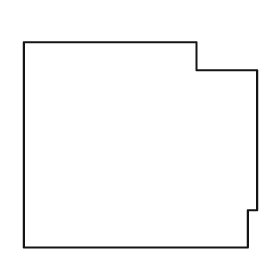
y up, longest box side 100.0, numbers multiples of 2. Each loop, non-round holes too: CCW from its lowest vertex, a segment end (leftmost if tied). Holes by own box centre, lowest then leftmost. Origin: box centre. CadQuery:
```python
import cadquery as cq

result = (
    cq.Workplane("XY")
    .moveTo(-50.0, -44.0)
    .lineTo(46.0, -44.0)
    .lineTo(46.0, -28.0)
    .lineTo(50.0, -28.0)
    .lineTo(50.0, 32.0)
    .lineTo(24.0, 32.0)
    .lineTo(24.0, 44.0)
    .lineTo(-50.0, 44.0)
    .close()
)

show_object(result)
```